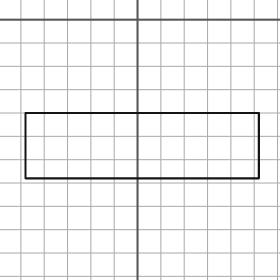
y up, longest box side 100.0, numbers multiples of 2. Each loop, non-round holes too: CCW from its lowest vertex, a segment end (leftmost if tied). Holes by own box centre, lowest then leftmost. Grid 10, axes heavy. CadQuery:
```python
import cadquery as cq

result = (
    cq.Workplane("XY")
    .moveTo(-48.0, -68.0)
    .lineTo(52.0, -68.0)
    .lineTo(52.0, -40.0)
    .lineTo(-48.0, -40.0)
    .close()
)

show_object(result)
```